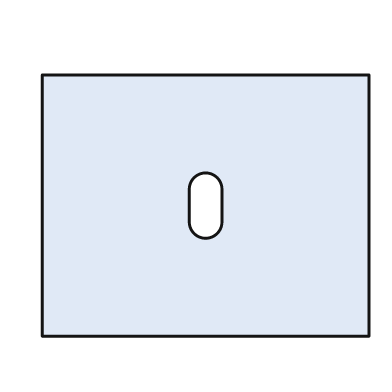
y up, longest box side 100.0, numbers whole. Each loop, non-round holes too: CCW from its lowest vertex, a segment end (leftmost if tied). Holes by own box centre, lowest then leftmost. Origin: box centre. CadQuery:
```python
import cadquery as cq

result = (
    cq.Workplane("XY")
    .moveTo(-50.0, -40.0)
    .lineTo(50.0, -40.0)
    .lineTo(50.0, 40.0)
    .lineTo(-50.0, 40.0)
    .close()
    .moveTo(-5.0, -5.0)
    .threePointArc((0.0, -10.0), (5.0, -5.0))
    .lineTo(5.0, 5.0)
    .threePointArc((0.0, 10.0), (-5.0, 5.0))
    .close()
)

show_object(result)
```